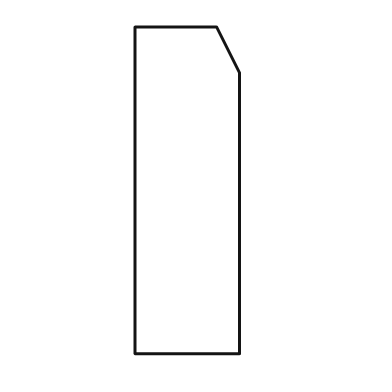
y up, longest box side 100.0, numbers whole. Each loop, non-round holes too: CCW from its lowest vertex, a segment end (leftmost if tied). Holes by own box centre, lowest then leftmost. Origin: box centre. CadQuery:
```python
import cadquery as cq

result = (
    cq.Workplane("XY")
    .moveTo(-16.0, -50.0)
    .lineTo(16.0, -50.0)
    .lineTo(16.0, 36.0)
    .lineTo(9.0, 50.0)
    .lineTo(-16.0, 50.0)
    .close()
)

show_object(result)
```